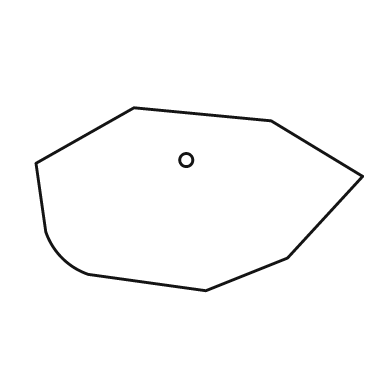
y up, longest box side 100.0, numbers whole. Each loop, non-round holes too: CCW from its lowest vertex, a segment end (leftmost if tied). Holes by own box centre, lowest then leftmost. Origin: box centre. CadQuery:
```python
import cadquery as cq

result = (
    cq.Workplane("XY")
    .moveTo(2.0, -28.0)
    .lineTo(27.0, -18.0)
    .lineTo(50.0, 7.0)
    .lineTo(22.0, 24.0)
    .lineTo(-20.0, 28.0)
    .lineTo(-50.0, 11.0)
    .lineTo(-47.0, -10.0)
    .threePointArc((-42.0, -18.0), (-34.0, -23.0))
    .close()
    .moveTo(-4.0, 12.0)
    .circle(2.0)
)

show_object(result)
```